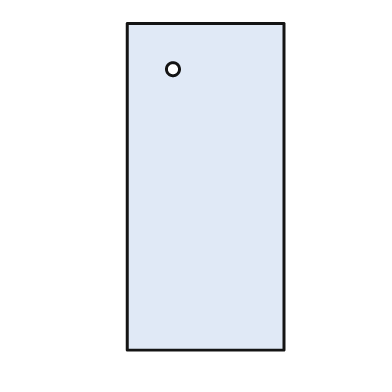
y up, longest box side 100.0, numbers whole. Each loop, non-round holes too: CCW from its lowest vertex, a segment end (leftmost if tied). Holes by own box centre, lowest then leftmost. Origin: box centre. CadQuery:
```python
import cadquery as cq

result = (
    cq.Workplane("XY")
    .moveTo(-24.0, -50.0)
    .lineTo(24.0, -50.0)
    .lineTo(24.0, 50.0)
    .lineTo(-24.0, 50.0)
    .close()
    .moveTo(-10.0, 36.0)
    .circle(2.0)
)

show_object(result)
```